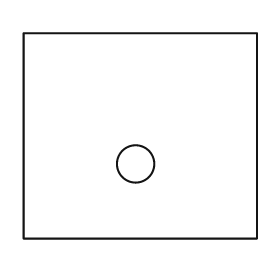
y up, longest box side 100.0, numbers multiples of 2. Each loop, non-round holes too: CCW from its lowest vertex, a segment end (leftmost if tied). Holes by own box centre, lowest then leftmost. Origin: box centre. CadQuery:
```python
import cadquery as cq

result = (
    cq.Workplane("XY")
    .moveTo(-50.0, -44.0)
    .lineTo(50.0, -44.0)
    .lineTo(50.0, 44.0)
    .lineTo(-50.0, 44.0)
    .close()
    .moveTo(-2.0, -12.0)
    .circle(8.0)
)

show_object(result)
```